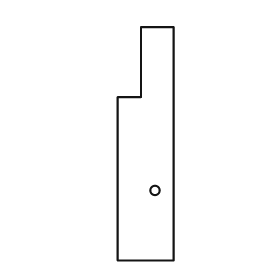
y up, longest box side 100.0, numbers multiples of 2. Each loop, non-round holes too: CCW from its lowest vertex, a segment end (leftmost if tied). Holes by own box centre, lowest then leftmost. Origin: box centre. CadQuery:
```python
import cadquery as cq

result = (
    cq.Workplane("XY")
    .moveTo(-12.0, -50.0)
    .lineTo(12.0, -50.0)
    .lineTo(12.0, 50.0)
    .lineTo(-2.0, 50.0)
    .lineTo(-2.0, 20.0)
    .lineTo(-12.0, 20.0)
    .close()
    .moveTo(4.0, -20.0)
    .circle(2.0)
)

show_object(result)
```